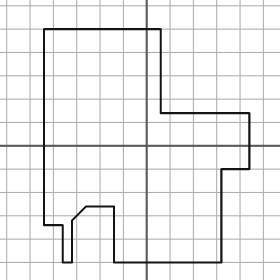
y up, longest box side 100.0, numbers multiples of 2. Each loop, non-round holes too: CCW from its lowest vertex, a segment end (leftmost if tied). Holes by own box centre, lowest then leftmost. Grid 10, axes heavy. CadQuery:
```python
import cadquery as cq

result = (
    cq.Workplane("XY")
    .moveTo(-36.0, -50.0)
    .lineTo(-32.0, -50.0)
    .lineTo(-32.0, -32.0)
    .lineTo(-26.0, -26.0)
    .lineTo(-14.0, -26.0)
    .lineTo(-14.0, -50.0)
    .lineTo(32.0, -50.0)
    .lineTo(32.0, -10.0)
    .lineTo(44.0, -10.0)
    .lineTo(44.0, 14.0)
    .lineTo(6.0, 14.0)
    .lineTo(6.0, 50.0)
    .lineTo(-44.0, 50.0)
    .lineTo(-44.0, -34.0)
    .lineTo(-36.0, -34.0)
    .close()
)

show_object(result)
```